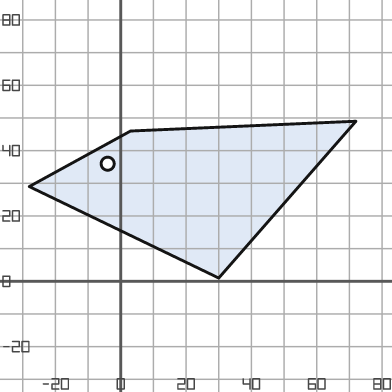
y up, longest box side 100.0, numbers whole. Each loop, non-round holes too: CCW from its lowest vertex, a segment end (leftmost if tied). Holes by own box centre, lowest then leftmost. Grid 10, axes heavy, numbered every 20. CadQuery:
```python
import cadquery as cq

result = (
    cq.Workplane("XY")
    .moveTo(30.0, 1.0)
    .lineTo(72.0, 49.0)
    .lineTo(3.0, 46.0)
    .lineTo(-28.0, 29.0)
    .close()
    .moveTo(-4.0, 36.0)
    .circle(2.0)
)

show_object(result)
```